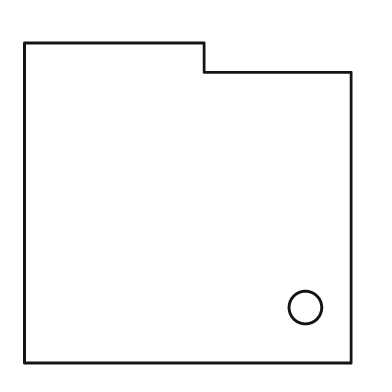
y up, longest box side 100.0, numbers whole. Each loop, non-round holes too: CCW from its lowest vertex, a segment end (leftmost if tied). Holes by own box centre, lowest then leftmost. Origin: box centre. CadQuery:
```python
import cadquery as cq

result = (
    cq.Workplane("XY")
    .moveTo(-50.0, -49.0)
    .lineTo(50.0, -49.0)
    .lineTo(50.0, 40.0)
    .lineTo(5.0, 40.0)
    .lineTo(5.0, 49.0)
    .lineTo(-50.0, 49.0)
    .close()
    .moveTo(36.0, -32.0)
    .circle(5.0)
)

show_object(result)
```